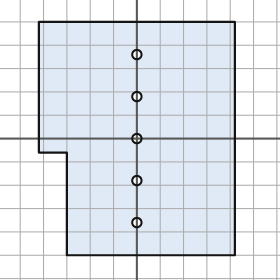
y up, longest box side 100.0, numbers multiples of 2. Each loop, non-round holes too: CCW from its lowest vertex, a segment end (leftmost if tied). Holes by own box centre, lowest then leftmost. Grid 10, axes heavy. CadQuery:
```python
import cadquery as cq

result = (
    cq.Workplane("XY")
    .moveTo(-30.0, -50.0)
    .lineTo(42.0, -50.0)
    .lineTo(42.0, 50.0)
    .lineTo(-42.0, 50.0)
    .lineTo(-42.0, -6.0)
    .lineTo(-30.0, -6.0)
    .close()
    .moveTo(0.0, -36.0)
    .circle(2.0)
    .moveTo(0.0, -18.0)
    .circle(2.0)
    .moveTo(0.0, 0.0)
    .circle(2.0)
    .moveTo(0.0, 18.0)
    .circle(2.0)
    .moveTo(0.0, 36.0)
    .circle(2.0)
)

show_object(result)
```